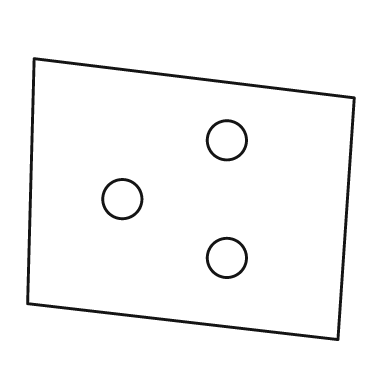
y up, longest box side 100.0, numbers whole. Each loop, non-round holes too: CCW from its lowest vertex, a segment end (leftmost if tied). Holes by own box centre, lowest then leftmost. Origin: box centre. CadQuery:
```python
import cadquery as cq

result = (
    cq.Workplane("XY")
    .moveTo(45.0, -43.0)
    .lineTo(50.0, 31.0)
    .lineTo(-48.0, 43.0)
    .lineTo(-50.0, -32.0)
    .close()
    .moveTo(11.0, -18.0)
    .circle(6.0)
    .moveTo(-21.0, 0.0)
    .circle(6.0)
    .moveTo(11.0, 18.0)
    .circle(6.0)
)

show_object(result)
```